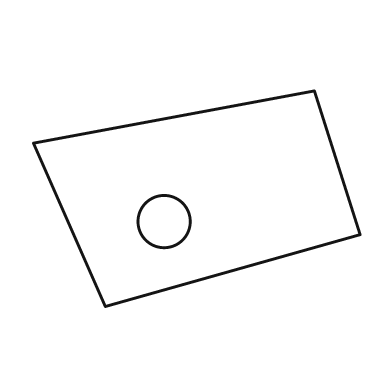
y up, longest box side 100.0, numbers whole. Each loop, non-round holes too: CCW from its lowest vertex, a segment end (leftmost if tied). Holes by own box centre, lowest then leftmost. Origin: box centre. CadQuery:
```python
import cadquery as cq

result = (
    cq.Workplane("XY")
    .moveTo(-28.0, -33.0)
    .lineTo(50.0, -11.0)
    .lineTo(36.0, 33.0)
    .lineTo(-50.0, 17.0)
    .close()
    .moveTo(-10.0, -7.0)
    .circle(8.0)
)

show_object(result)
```